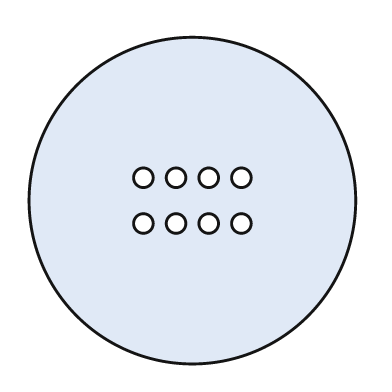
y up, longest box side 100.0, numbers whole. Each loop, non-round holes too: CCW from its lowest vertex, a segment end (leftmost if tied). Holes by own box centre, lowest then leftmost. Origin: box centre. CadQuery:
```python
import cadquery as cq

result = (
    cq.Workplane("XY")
    .moveTo(0.0, 0.0)
    .circle(50.0)
    .moveTo(-15.0, -7.0)
    .circle(3.0)
    .moveTo(-5.0, -7.0)
    .circle(3.0)
    .moveTo(5.0, -7.0)
    .circle(3.0)
    .moveTo(15.0, -7.0)
    .circle(3.0)
    .moveTo(-15.0, 7.0)
    .circle(3.0)
    .moveTo(-5.0, 7.0)
    .circle(3.0)
    .moveTo(5.0, 7.0)
    .circle(3.0)
    .moveTo(15.0, 7.0)
    .circle(3.0)
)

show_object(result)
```